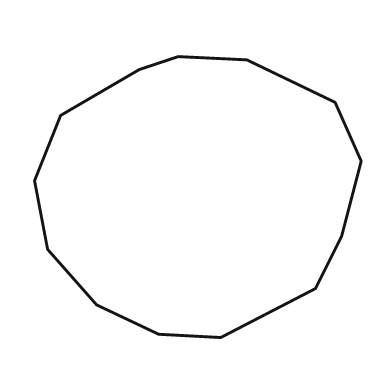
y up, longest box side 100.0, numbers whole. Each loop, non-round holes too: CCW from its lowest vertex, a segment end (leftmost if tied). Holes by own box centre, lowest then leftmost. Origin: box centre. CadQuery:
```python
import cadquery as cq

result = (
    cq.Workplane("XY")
    .moveTo(7.0, -43.0)
    .lineTo(36.0, -28.0)
    .lineTo(44.0, -12.0)
    .lineTo(50.0, 11.0)
    .lineTo(42.0, 29.0)
    .lineTo(15.0, 42.0)
    .lineTo(-6.0, 43.0)
    .lineTo(-18.0, 39.0)
    .lineTo(-42.0, 25.0)
    .lineTo(-50.0, 5.0)
    .lineTo(-46.0, -16.0)
    .lineTo(-31.0, -33.0)
    .lineTo(-12.0, -42.0)
    .close()
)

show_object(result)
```